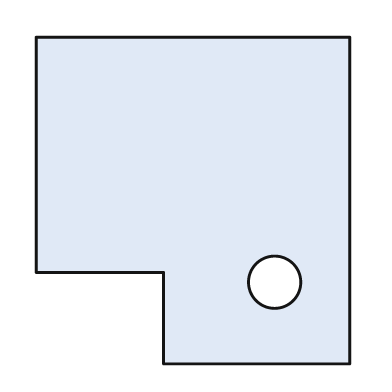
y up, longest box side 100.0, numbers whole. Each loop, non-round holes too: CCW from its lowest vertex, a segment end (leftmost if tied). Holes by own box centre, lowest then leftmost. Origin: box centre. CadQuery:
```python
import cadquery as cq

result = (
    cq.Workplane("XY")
    .moveTo(-9.0, -50.0)
    .lineTo(48.0, -50.0)
    .lineTo(48.0, 50.0)
    .lineTo(-48.0, 50.0)
    .lineTo(-48.0, -22.0)
    .lineTo(-9.0, -22.0)
    .close()
    .moveTo(25.0, -25.0)
    .circle(8.0)
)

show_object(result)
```